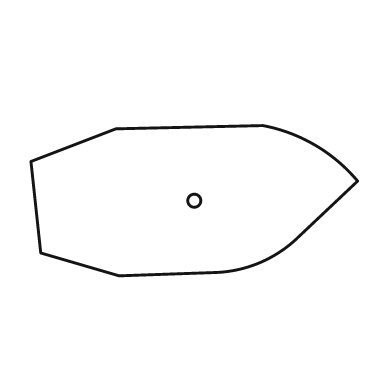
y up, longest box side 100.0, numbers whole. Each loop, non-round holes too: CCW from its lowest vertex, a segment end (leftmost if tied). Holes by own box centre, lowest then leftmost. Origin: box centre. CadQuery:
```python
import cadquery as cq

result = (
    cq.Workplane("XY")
    .moveTo(-23.0, -23.0)
    .lineTo(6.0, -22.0)
    .threePointArc((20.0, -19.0), (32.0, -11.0))
    .lineTo(50.0, 6.0)
    .threePointArc((37.0, 17.0), (21.0, 23.0))
    .lineTo(-24.0, 22.0)
    .lineTo(-50.0, 12.0)
    .lineTo(-47.0, -16.0)
    .close()
    .moveTo(0.0, 0.0)
    .circle(2.0)
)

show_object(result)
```